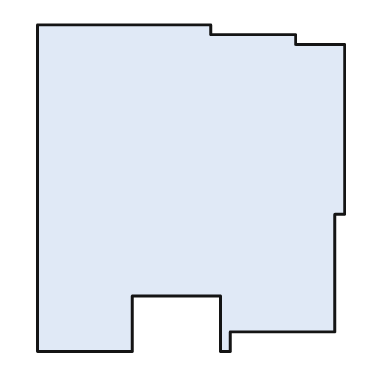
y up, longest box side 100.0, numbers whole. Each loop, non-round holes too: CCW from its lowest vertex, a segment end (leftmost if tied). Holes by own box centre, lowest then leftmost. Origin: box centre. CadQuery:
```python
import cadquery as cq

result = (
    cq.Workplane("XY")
    .moveTo(-47.0, -50.0)
    .lineTo(-18.0, -50.0)
    .lineTo(-18.0, -33.0)
    .lineTo(9.0, -33.0)
    .lineTo(9.0, -50.0)
    .lineTo(12.0, -50.0)
    .lineTo(12.0, -44.0)
    .lineTo(44.0, -44.0)
    .lineTo(44.0, -8.0)
    .lineTo(47.0, -8.0)
    .lineTo(47.0, 44.0)
    .lineTo(32.0, 44.0)
    .lineTo(32.0, 47.0)
    .lineTo(6.0, 47.0)
    .lineTo(6.0, 50.0)
    .lineTo(-47.0, 50.0)
    .close()
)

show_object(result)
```